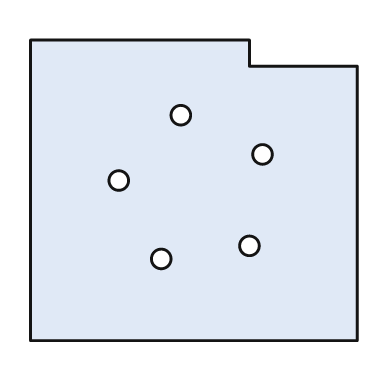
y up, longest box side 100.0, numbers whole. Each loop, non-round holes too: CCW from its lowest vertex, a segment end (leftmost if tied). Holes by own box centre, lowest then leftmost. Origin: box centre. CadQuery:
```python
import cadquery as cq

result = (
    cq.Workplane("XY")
    .moveTo(-50.0, -46.0)
    .lineTo(50.0, -46.0)
    .lineTo(50.0, 38.0)
    .lineTo(17.0, 38.0)
    .lineTo(17.0, 46.0)
    .lineTo(-50.0, 46.0)
    .close()
    .moveTo(-10.0, -21.0)
    .circle(3.0)
    .moveTo(17.0, -17.0)
    .circle(3.0)
    .moveTo(-23.0, 3.0)
    .circle(3.0)
    .moveTo(21.0, 11.0)
    .circle(3.0)
    .moveTo(-4.0, 23.0)
    .circle(3.0)
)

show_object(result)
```